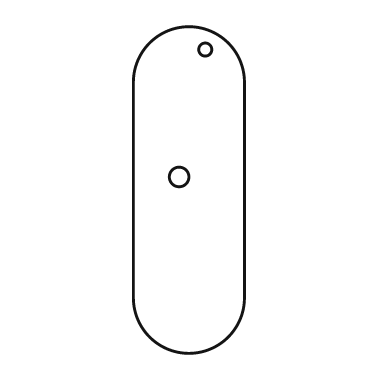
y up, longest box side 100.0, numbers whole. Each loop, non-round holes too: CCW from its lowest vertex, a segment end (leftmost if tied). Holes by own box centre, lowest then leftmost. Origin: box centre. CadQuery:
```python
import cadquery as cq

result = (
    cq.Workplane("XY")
    .moveTo(-17.0, -33.0)
    .threePointArc((0.0, -50.0), (17.0, -33.0))
    .lineTo(17.0, 33.0)
    .threePointArc((0.0, 50.0), (-17.0, 33.0))
    .close()
    .moveTo(-3.0, 4.0)
    .circle(3.0)
    .moveTo(5.0, 43.0)
    .circle(2.0)
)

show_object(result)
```